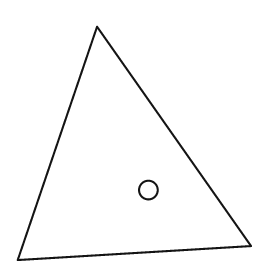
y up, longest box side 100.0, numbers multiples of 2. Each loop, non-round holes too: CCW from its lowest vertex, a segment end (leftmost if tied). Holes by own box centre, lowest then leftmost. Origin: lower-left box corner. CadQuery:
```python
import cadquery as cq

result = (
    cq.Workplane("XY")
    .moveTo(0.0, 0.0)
    .lineTo(100.0, 6.0)
    .lineTo(34.0, 100.0)
    .close()
    .moveTo(56.0, 30.0)
    .circle(4.0)
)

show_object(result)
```